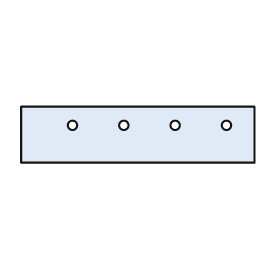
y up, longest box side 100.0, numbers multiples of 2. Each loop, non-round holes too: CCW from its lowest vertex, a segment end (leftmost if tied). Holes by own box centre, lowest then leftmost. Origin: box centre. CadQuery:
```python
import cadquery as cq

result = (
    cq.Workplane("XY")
    .moveTo(-50.0, -12.0)
    .lineTo(50.0, -12.0)
    .lineTo(50.0, 12.0)
    .lineTo(-50.0, 12.0)
    .close()
    .moveTo(-28.0, 4.0)
    .circle(2.0)
    .moveTo(-6.0, 4.0)
    .circle(2.0)
    .moveTo(16.0, 4.0)
    .circle(2.0)
    .moveTo(38.0, 4.0)
    .circle(2.0)
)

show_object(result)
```